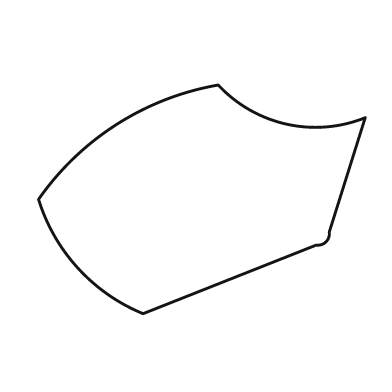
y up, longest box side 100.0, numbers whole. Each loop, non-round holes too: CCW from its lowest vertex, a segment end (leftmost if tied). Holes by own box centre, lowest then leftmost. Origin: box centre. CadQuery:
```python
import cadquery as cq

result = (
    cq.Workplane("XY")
    .moveTo(-18.0, -35.0)
    .lineTo(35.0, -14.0)
    .threePointArc((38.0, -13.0), (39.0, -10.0))
    .lineTo(50.0, 25.0)
    .threePointArc((26.0, 23.0), (5.0, 35.0))
    .threePointArc((-26.0, 23.0), (-50.0, 0.0))
    .threePointArc((-38.0, -21.0), (-18.0, -35.0))
    .close()
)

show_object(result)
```